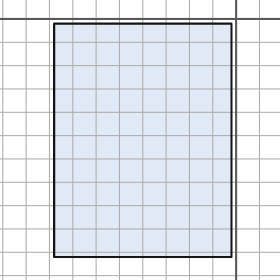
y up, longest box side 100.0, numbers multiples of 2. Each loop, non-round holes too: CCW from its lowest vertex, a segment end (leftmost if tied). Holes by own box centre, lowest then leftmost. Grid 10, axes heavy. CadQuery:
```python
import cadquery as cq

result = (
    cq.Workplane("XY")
    .moveTo(-78.0, -102.0)
    .lineTo(-2.0, -102.0)
    .lineTo(-2.0, -2.0)
    .lineTo(-78.0, -2.0)
    .close()
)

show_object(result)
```